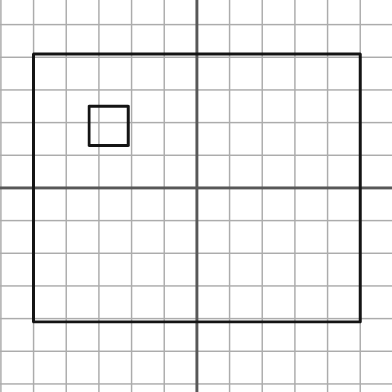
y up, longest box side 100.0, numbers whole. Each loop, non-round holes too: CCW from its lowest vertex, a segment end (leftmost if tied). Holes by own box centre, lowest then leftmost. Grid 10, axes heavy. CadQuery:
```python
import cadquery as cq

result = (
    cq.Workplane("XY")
    .moveTo(-50.0, -41.0)
    .lineTo(50.0, -41.0)
    .lineTo(50.0, 41.0)
    .lineTo(-50.0, 41.0)
    .close()
    .moveTo(-33.0, 13.0)
    .lineTo(-21.0, 13.0)
    .lineTo(-21.0, 25.0)
    .lineTo(-33.0, 25.0)
    .close()
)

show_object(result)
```